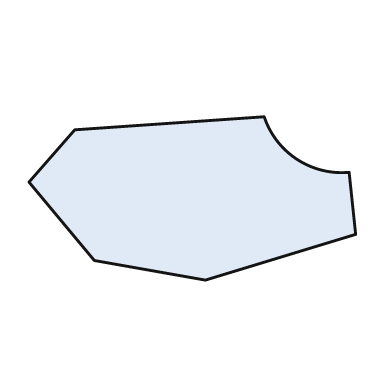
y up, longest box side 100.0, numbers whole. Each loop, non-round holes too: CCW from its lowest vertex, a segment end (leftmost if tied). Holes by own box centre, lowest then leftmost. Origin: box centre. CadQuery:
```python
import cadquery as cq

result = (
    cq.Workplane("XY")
    .moveTo(4.0, -25.0)
    .lineTo(50.0, -11.0)
    .lineTo(48.0, 8.0)
    .threePointArc((32.0, 12.0), (22.0, 25.0))
    .lineTo(-36.0, 21.0)
    .lineTo(-50.0, 5.0)
    .lineTo(-30.0, -19.0)
    .close()
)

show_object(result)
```